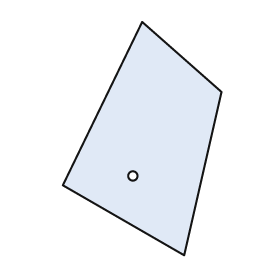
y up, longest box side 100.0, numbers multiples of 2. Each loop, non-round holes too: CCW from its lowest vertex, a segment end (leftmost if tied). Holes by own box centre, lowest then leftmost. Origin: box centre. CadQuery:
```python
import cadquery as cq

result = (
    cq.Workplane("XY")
    .moveTo(18.0, -50.0)
    .lineTo(34.0, 20.0)
    .lineTo(0.0, 50.0)
    .lineTo(-34.0, -20.0)
    .close()
    .moveTo(-4.0, -16.0)
    .circle(2.0)
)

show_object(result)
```